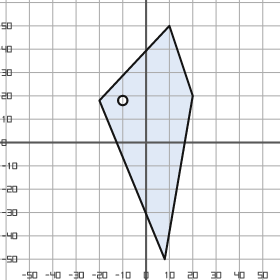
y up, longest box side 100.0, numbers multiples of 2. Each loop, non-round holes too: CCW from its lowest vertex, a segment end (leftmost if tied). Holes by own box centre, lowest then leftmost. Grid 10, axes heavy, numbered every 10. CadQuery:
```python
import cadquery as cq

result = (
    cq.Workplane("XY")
    .moveTo(8.0, -50.0)
    .lineTo(20.0, 20.0)
    .lineTo(10.0, 50.0)
    .lineTo(-20.0, 18.0)
    .close()
    .moveTo(-10.0, 18.0)
    .circle(2.0)
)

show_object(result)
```